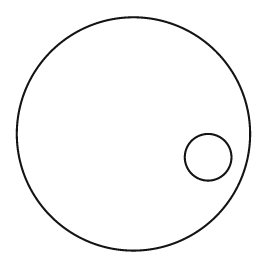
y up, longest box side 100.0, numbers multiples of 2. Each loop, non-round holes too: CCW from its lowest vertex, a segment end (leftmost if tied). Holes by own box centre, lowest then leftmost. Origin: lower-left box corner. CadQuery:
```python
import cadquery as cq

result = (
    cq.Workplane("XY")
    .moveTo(50.0, 50.0)
    .circle(50.0)
    .moveTo(82.0, 40.0)
    .circle(10.0)
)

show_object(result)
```